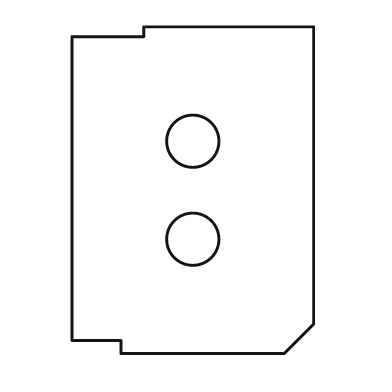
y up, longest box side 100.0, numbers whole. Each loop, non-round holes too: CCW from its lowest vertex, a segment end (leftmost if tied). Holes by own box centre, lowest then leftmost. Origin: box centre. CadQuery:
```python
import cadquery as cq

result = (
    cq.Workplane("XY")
    .moveTo(-22.0, -50.0)
    .lineTo(28.0, -50.0)
    .lineTo(37.0, -41.0)
    .lineTo(37.0, 50.0)
    .lineTo(-15.0, 50.0)
    .lineTo(-15.0, 47.0)
    .lineTo(-37.0, 47.0)
    .lineTo(-37.0, -46.0)
    .lineTo(-22.0, -46.0)
    .close()
    .moveTo(0.0, -15.0)
    .circle(8.0)
    .moveTo(0.0, 15.0)
    .circle(8.0)
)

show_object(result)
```